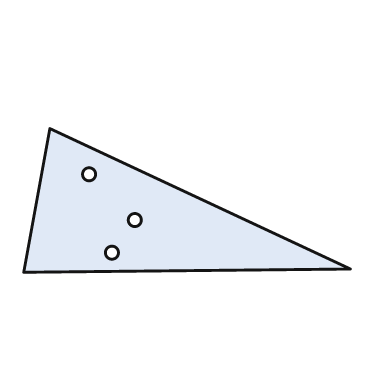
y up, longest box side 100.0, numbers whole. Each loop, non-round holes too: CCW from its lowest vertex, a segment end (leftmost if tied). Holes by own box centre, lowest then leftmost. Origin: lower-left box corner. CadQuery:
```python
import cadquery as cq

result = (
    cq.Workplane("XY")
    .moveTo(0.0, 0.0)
    .lineTo(100.0, 1.0)
    .lineTo(8.0, 44.0)
    .close()
    .moveTo(27.0, 6.0)
    .circle(2.0)
    .moveTo(34.0, 16.0)
    .circle(2.0)
    .moveTo(20.0, 30.0)
    .circle(2.0)
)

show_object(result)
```